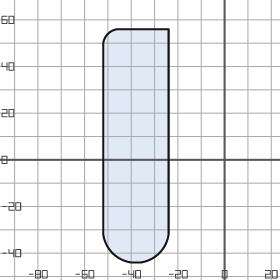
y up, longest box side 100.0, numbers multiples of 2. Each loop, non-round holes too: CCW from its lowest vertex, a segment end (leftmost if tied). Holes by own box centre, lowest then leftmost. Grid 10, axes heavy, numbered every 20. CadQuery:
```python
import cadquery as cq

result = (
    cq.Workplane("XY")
    .moveTo(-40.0, -44.0)
    .lineTo(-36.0, -44.0)
    .threePointArc((-28.0, -40.0), (-24.0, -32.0))
    .lineTo(-24.0, 56.0)
    .lineTo(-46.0, 56.0)
    .threePointArc((-50.0, 54.0), (-52.0, 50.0))
    .lineTo(-52.0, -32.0)
    .threePointArc((-48.0, -40.0), (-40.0, -44.0))
    .close()
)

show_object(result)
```